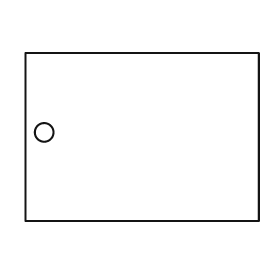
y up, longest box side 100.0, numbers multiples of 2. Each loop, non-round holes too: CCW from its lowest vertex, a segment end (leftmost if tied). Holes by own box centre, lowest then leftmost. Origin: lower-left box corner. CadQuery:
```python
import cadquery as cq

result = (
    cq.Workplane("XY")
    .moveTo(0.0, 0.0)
    .lineTo(100.0, 0.0)
    .lineTo(100.0, 72.0)
    .lineTo(0.0, 72.0)
    .close()
    .moveTo(8.0, 38.0)
    .circle(4.0)
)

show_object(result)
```